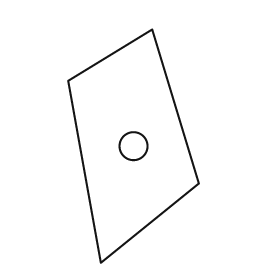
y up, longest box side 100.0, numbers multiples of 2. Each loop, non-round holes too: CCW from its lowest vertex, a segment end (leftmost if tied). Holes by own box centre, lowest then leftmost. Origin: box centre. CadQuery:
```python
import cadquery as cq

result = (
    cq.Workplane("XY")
    .moveTo(-14.0, -50.0)
    .lineTo(28.0, -16.0)
    .lineTo(8.0, 50.0)
    .lineTo(-28.0, 28.0)
    .close()
    .moveTo(0.0, 0.0)
    .circle(6.0)
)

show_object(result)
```